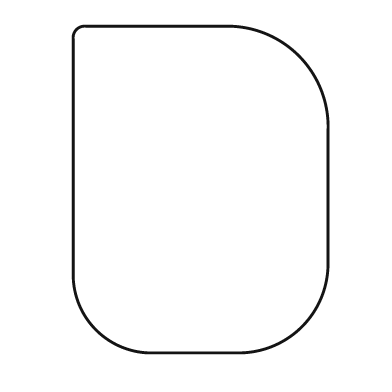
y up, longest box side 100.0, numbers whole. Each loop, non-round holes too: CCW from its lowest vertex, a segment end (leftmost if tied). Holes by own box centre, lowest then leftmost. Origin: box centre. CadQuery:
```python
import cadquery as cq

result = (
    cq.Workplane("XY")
    .moveTo(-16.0, -50.0)
    .lineTo(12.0, -50.0)
    .threePointArc((31.0, -42.0), (39.0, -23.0))
    .lineTo(39.0, 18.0)
    .threePointArc((30.0, 41.0), (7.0, 50.0))
    .lineTo(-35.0, 50.0)
    .threePointArc((-38.0, 49.0), (-39.0, 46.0))
    .lineTo(-39.0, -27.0)
    .threePointArc((-32.0, -43.0), (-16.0, -50.0))
    .close()
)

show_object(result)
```